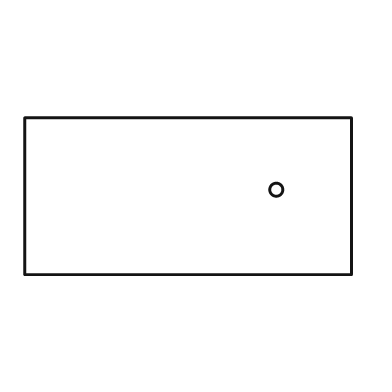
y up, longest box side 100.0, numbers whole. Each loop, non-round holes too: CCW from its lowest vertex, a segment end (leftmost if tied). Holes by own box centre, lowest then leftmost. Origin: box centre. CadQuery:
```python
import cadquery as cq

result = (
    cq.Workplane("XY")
    .moveTo(-50.0, -24.0)
    .lineTo(50.0, -24.0)
    .lineTo(50.0, 24.0)
    .lineTo(-50.0, 24.0)
    .close()
    .moveTo(27.0, 2.0)
    .circle(2.0)
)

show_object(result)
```